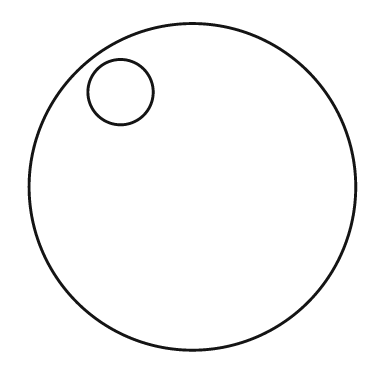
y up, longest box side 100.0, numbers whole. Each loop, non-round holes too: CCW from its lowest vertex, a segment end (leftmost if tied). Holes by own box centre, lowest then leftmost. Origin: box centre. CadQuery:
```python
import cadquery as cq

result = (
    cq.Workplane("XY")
    .moveTo(0.0, 0.0)
    .circle(50.0)
    .moveTo(-22.0, 29.0)
    .circle(10.0)
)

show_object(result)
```